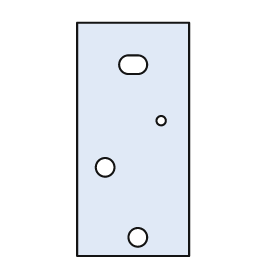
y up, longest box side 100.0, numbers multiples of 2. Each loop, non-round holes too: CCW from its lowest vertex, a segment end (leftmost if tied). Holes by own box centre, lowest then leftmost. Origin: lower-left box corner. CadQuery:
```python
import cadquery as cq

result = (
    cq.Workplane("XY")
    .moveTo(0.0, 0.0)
    .lineTo(48.0, 0.0)
    .lineTo(48.0, 100.0)
    .lineTo(0.0, 100.0)
    .close()
    .moveTo(26.0, 8.0)
    .circle(4.0)
    .moveTo(12.0, 38.0)
    .circle(4.0)
    .moveTo(36.0, 58.0)
    .circle(2.0)
    .moveTo(22.0, 78.0)
    .lineTo(26.0, 78.0)
    .threePointArc((30.0, 82.0), (26.0, 86.0))
    .lineTo(22.0, 86.0)
    .threePointArc((18.0, 82.0), (22.0, 78.0))
    .close()
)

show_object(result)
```